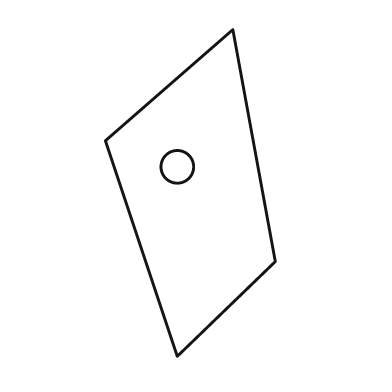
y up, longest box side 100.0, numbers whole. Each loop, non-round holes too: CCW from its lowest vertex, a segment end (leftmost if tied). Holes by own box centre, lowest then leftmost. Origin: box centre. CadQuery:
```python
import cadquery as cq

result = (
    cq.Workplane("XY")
    .moveTo(-4.0, -50.0)
    .lineTo(26.0, -21.0)
    .lineTo(13.0, 50.0)
    .lineTo(-26.0, 16.0)
    .close()
    .moveTo(-4.0, 8.0)
    .circle(5.0)
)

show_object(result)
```